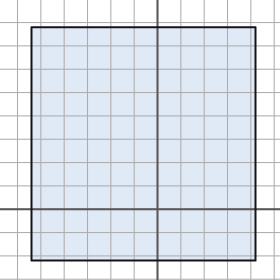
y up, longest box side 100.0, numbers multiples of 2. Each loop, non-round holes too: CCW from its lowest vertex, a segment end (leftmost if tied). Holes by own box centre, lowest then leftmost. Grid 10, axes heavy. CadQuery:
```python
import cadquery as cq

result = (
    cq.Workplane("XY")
    .moveTo(-54.0, -22.0)
    .lineTo(42.0, -22.0)
    .lineTo(42.0, 78.0)
    .lineTo(-54.0, 78.0)
    .close()
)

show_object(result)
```